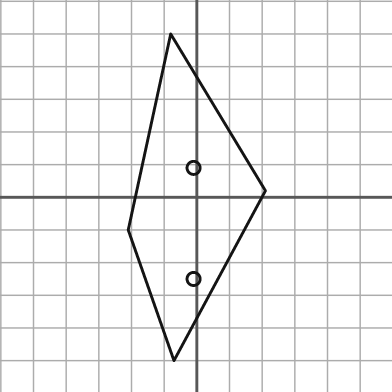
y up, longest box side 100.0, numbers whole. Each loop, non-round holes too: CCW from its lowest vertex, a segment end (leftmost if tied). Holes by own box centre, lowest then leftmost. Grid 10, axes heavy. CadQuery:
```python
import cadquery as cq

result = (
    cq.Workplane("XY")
    .moveTo(-7.0, -50.0)
    .lineTo(21.0, 2.0)
    .lineTo(-8.0, 50.0)
    .lineTo(-21.0, -10.0)
    .close()
    .moveTo(-1.0, -25.0)
    .circle(2.0)
    .moveTo(-1.0, 9.0)
    .circle(2.0)
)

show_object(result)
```